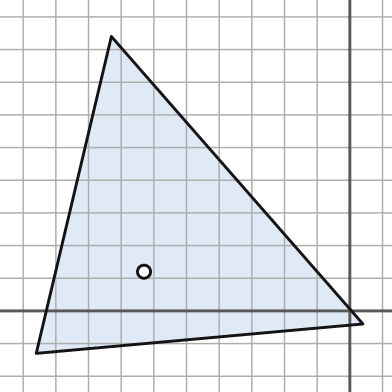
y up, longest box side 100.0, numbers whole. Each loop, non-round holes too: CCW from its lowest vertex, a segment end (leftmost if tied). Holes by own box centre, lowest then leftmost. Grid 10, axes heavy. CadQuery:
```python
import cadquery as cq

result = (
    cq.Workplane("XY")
    .moveTo(-96.0, -13.0)
    .lineTo(4.0, -4.0)
    .lineTo(-73.0, 84.0)
    .close()
    .moveTo(-63.0, 12.0)
    .circle(2.0)
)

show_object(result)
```